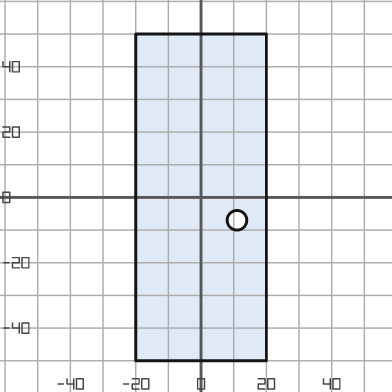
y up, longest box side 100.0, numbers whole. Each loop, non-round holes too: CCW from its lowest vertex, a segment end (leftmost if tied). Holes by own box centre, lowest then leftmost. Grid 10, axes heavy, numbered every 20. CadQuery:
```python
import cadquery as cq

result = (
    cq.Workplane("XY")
    .moveTo(-20.0, -50.0)
    .lineTo(20.0, -50.0)
    .lineTo(20.0, 50.0)
    .lineTo(-20.0, 50.0)
    .close()
    .moveTo(11.0, -7.0)
    .circle(3.0)
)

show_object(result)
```